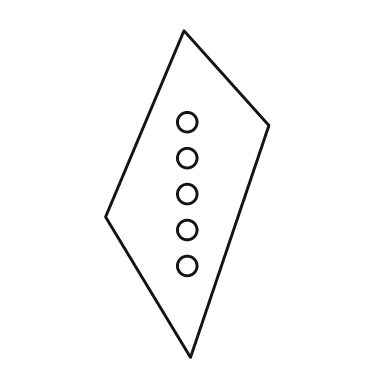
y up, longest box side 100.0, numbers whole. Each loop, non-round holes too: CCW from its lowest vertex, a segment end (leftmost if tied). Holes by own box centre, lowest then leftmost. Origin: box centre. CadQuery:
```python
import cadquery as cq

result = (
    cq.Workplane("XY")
    .moveTo(1.0, -50.0)
    .lineTo(25.0, 21.0)
    .lineTo(-1.0, 50.0)
    .lineTo(-25.0, -7.0)
    .close()
    .moveTo(0.0, -22.0)
    .circle(3.0)
    .moveTo(0.0, -11.0)
    .circle(3.0)
    .moveTo(0.0, 0.0)
    .circle(3.0)
    .moveTo(0.0, 11.0)
    .circle(3.0)
    .moveTo(0.0, 22.0)
    .circle(3.0)
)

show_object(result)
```